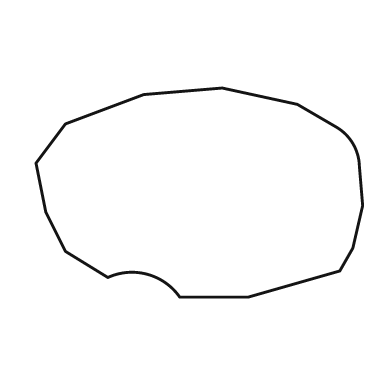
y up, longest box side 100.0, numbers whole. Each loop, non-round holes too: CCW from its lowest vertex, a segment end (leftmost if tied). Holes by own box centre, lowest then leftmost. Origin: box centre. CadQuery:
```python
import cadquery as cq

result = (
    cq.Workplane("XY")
    .moveTo(-6.0, -32.0)
    .lineTo(15.0, -32.0)
    .lineTo(43.0, -24.0)
    .lineTo(47.0, -17.0)
    .lineTo(50.0, -4.0)
    .lineTo(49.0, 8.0)
    .threePointArc((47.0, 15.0), (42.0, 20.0))
    .lineTo(30.0, 27.0)
    .lineTo(7.0, 32.0)
    .lineTo(-17.0, 30.0)
    .lineTo(-41.0, 21.0)
    .lineTo(-50.0, 9.0)
    .lineTo(-47.0, -6.0)
    .lineTo(-41.0, -18.0)
    .lineTo(-28.0, -26.0)
    .threePointArc((-16.0, -25.0), (-6.0, -32.0))
    .close()
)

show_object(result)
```